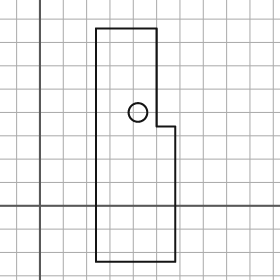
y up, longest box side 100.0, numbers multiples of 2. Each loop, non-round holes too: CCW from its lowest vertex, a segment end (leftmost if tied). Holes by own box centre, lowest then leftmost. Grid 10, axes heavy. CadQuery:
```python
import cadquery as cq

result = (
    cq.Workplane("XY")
    .moveTo(24.0, -24.0)
    .lineTo(58.0, -24.0)
    .lineTo(58.0, 34.0)
    .lineTo(50.0, 34.0)
    .lineTo(50.0, 76.0)
    .lineTo(24.0, 76.0)
    .close()
    .moveTo(42.0, 40.0)
    .circle(4.0)
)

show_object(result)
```